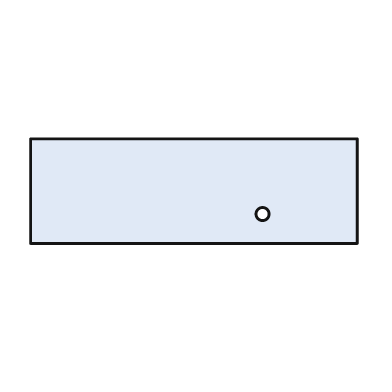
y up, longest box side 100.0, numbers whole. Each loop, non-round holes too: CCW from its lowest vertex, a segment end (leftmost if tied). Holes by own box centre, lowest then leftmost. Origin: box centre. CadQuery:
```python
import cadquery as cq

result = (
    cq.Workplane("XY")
    .moveTo(-50.0, -16.0)
    .lineTo(50.0, -16.0)
    .lineTo(50.0, 16.0)
    .lineTo(-50.0, 16.0)
    .close()
    .moveTo(21.0, -7.0)
    .circle(2.0)
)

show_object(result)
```